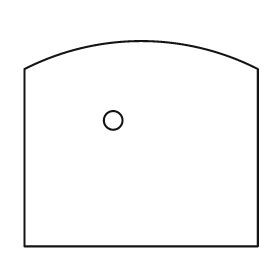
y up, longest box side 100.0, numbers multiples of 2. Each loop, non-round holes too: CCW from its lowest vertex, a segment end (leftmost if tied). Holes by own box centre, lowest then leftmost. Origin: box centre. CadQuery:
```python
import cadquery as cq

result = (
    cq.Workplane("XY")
    .moveTo(-50.0, -44.0)
    .lineTo(50.0, -44.0)
    .lineTo(50.0, 32.0)
    .threePointArc((0.0, 44.0), (-50.0, 32.0))
    .close()
    .moveTo(-12.0, 10.0)
    .circle(4.0)
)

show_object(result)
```